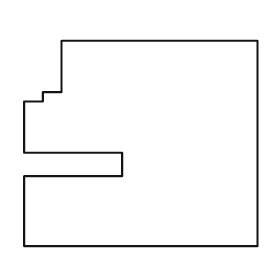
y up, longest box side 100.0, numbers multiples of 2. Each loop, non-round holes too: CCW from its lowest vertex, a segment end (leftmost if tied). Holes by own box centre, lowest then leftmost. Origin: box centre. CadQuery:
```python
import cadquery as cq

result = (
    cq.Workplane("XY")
    .moveTo(-50.0, -44.0)
    .lineTo(50.0, -44.0)
    .lineTo(50.0, 44.0)
    .lineTo(-34.0, 44.0)
    .lineTo(-34.0, 22.0)
    .lineTo(-42.0, 22.0)
    .lineTo(-42.0, 18.0)
    .lineTo(-50.0, 18.0)
    .lineTo(-50.0, -4.0)
    .lineTo(-8.0, -4.0)
    .lineTo(-8.0, -14.0)
    .lineTo(-50.0, -14.0)
    .close()
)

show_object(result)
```